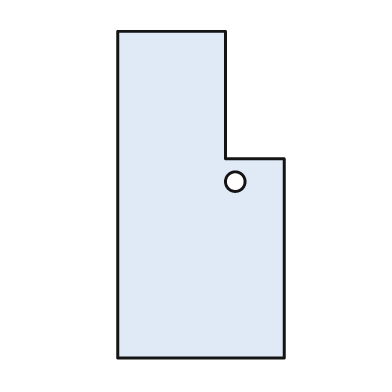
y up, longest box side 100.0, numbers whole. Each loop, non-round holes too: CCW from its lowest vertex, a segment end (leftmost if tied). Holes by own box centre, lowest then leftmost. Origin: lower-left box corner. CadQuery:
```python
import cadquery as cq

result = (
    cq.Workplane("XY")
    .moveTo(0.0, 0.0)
    .lineTo(51.0, 0.0)
    .lineTo(51.0, 61.0)
    .lineTo(33.0, 61.0)
    .lineTo(33.0, 100.0)
    .lineTo(0.0, 100.0)
    .close()
    .moveTo(36.0, 54.0)
    .circle(3.0)
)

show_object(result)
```